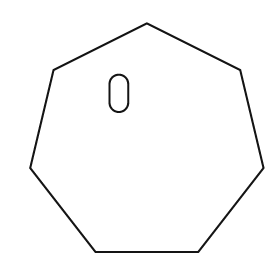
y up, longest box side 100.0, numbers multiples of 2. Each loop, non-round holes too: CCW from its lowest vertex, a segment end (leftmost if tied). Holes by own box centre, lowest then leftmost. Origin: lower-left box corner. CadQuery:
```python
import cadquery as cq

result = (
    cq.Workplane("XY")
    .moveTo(28.0, 0.0)
    .lineTo(72.0, 0.0)
    .lineTo(100.0, 36.0)
    .lineTo(90.0, 78.0)
    .lineTo(50.0, 98.0)
    .lineTo(10.0, 78.0)
    .lineTo(0.0, 36.0)
    .close()
    .moveTo(34.0, 64.0)
    .threePointArc((38.0, 60.0), (42.0, 64.0))
    .lineTo(42.0, 72.0)
    .threePointArc((38.0, 76.0), (34.0, 72.0))
    .close()
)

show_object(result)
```